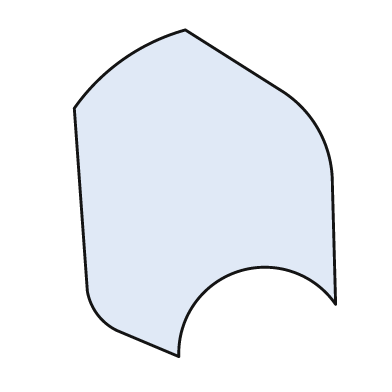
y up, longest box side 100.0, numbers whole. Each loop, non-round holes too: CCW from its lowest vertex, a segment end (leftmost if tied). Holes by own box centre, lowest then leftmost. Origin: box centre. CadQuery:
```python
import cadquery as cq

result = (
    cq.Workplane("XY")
    .moveTo(-8.0, -50.0)
    .threePointArc((10.0, -24.0), (40.0, -34.0))
    .lineTo(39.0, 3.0)
    .threePointArc((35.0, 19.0), (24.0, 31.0))
    .lineTo(-6.0, 50.0)
    .threePointArc((-25.0, 41.0), (-40.0, 26.0))
    .lineTo(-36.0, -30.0)
    .threePointArc((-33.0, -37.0), (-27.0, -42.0))
    .close()
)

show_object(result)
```